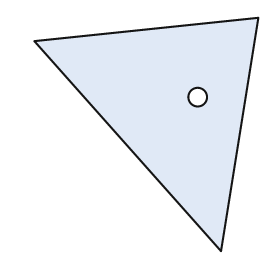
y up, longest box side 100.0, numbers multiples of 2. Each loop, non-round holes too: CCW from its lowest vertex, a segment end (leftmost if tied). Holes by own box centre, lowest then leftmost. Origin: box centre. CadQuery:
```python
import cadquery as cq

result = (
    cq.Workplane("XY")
    .moveTo(32.0, -50.0)
    .lineTo(48.0, 50.0)
    .lineTo(-48.0, 40.0)
    .close()
    .moveTo(22.0, 16.0)
    .circle(4.0)
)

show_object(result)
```